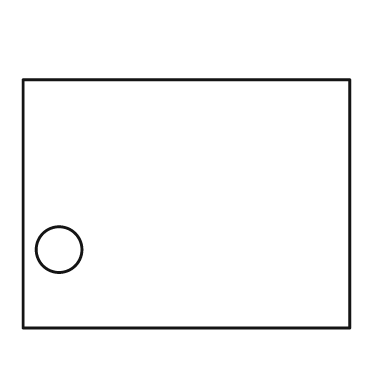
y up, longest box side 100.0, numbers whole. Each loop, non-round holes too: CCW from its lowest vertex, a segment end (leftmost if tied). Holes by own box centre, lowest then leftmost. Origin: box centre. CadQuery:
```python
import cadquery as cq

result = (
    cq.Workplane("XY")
    .moveTo(-50.0, -38.0)
    .lineTo(50.0, -38.0)
    .lineTo(50.0, 38.0)
    .lineTo(-50.0, 38.0)
    .close()
    .moveTo(-39.0, -14.0)
    .circle(7.0)
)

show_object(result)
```